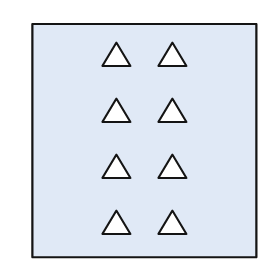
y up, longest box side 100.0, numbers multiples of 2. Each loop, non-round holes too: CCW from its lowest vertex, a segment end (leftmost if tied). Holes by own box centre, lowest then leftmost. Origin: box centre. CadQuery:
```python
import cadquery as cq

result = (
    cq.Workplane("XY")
    .moveTo(-48.0, -50.0)
    .lineTo(48.0, -50.0)
    .lineTo(48.0, 50.0)
    .lineTo(-48.0, 50.0)
    .close()
    .moveTo(-18.0, -40.0)
    .lineTo(-6.0, -40.0)
    .lineTo(-12.0, -30.0)
    .close()
    .moveTo(6.0, -40.0)
    .lineTo(18.0, -40.0)
    .lineTo(12.0, -30.0)
    .close()
    .moveTo(-18.0, -16.0)
    .lineTo(-6.0, -16.0)
    .lineTo(-12.0, -6.0)
    .close()
    .moveTo(6.0, -16.0)
    .lineTo(18.0, -16.0)
    .lineTo(12.0, -6.0)
    .close()
    .moveTo(-18.0, 8.0)
    .lineTo(-6.0, 8.0)
    .lineTo(-12.0, 18.0)
    .close()
    .moveTo(6.0, 8.0)
    .lineTo(18.0, 8.0)
    .lineTo(12.0, 18.0)
    .close()
    .moveTo(-18.0, 32.0)
    .lineTo(-6.0, 32.0)
    .lineTo(-12.0, 42.0)
    .close()
    .moveTo(6.0, 32.0)
    .lineTo(18.0, 32.0)
    .lineTo(12.0, 42.0)
    .close()
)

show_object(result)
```